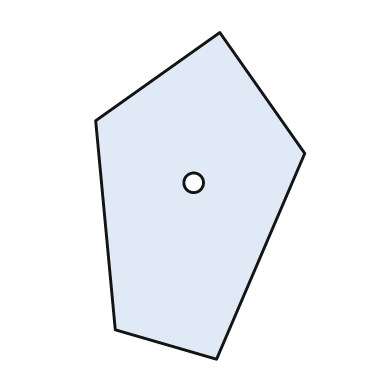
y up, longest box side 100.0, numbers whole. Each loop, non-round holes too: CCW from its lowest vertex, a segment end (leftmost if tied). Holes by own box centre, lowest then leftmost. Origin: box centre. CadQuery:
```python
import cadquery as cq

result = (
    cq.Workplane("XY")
    .moveTo(5.0, -50.0)
    .lineTo(32.0, 13.0)
    .lineTo(6.0, 50.0)
    .lineTo(-32.0, 23.0)
    .lineTo(-26.0, -41.0)
    .close()
    .moveTo(-2.0, 4.0)
    .circle(3.0)
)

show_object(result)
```